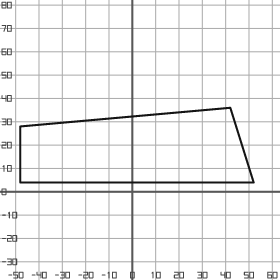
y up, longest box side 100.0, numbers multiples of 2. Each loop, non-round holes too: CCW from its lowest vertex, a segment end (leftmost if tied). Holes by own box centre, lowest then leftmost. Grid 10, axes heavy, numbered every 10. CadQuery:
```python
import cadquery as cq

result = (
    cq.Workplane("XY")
    .moveTo(-48.0, 4.0)
    .lineTo(52.0, 4.0)
    .lineTo(42.0, 36.0)
    .lineTo(-48.0, 28.0)
    .close()
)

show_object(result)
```